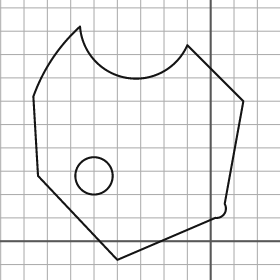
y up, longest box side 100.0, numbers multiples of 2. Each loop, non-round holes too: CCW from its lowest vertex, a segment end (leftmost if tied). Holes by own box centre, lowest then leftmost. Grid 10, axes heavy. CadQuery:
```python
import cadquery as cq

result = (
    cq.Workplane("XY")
    .moveTo(-40.0, -8.0)
    .lineTo(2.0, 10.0)
    .threePointArc((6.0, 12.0), (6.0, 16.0))
    .lineTo(14.0, 60.0)
    .lineTo(-10.0, 84.0)
    .threePointArc((-36.0, 70.0), (-56.0, 92.0))
    .threePointArc((-68.0, 78.0), (-76.0, 62.0))
    .lineTo(-74.0, 28.0)
    .close()
    .moveTo(-50.0, 28.0)
    .circle(8.0)
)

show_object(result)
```